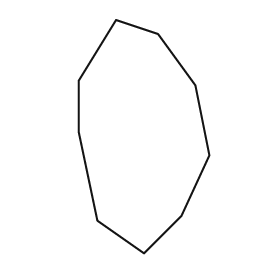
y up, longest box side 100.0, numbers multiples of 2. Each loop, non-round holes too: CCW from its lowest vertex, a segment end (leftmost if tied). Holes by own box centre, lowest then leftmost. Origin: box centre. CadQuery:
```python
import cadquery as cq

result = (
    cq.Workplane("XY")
    .moveTo(0.0, -50.0)
    .lineTo(16.0, -34.0)
    .lineTo(28.0, -8.0)
    .lineTo(22.0, 22.0)
    .lineTo(6.0, 44.0)
    .lineTo(-12.0, 50.0)
    .lineTo(-28.0, 24.0)
    .lineTo(-28.0, 2.0)
    .lineTo(-20.0, -36.0)
    .close()
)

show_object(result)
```